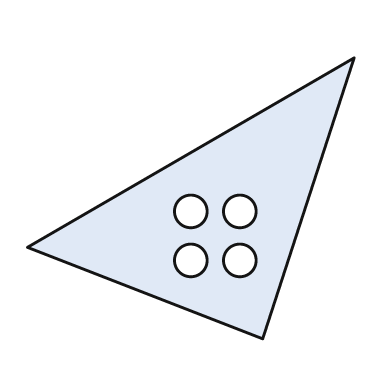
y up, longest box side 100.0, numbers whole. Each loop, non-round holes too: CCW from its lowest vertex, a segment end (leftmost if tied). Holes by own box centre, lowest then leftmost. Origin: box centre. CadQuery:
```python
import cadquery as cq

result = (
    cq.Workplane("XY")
    .moveTo(22.0, -43.0)
    .lineTo(50.0, 43.0)
    .lineTo(-50.0, -15.0)
    .close()
    .moveTo(0.0, -19.0)
    .circle(5.0)
    .moveTo(15.0, -19.0)
    .circle(5.0)
    .moveTo(0.0, -4.0)
    .circle(5.0)
    .moveTo(15.0, -4.0)
    .circle(5.0)
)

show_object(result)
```